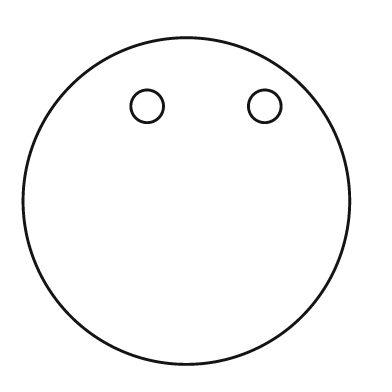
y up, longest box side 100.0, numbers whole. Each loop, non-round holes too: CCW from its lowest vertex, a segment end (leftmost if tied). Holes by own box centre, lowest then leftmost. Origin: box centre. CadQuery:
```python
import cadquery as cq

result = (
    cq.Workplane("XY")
    .moveTo(0.0, 0.0)
    .circle(50.0)
    .moveTo(-12.0, 29.0)
    .circle(5.0)
    .moveTo(24.0, 29.0)
    .circle(5.0)
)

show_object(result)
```